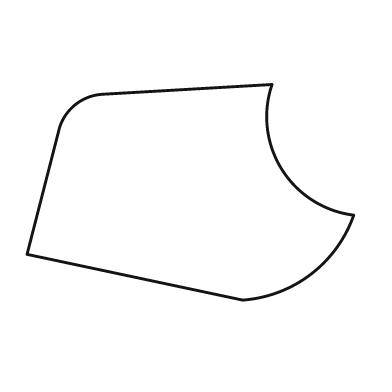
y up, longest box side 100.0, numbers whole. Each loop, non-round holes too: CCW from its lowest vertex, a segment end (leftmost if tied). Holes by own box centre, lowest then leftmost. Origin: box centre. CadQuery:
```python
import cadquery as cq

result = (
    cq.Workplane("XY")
    .moveTo(16.0, -33.0)
    .threePointArc((37.0, -25.0), (50.0, -7.0))
    .threePointArc((28.0, 7.0), (25.0, 33.0))
    .lineTo(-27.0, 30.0)
    .threePointArc((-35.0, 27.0), (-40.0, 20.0))
    .lineTo(-50.0, -19.0)
    .close()
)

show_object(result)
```